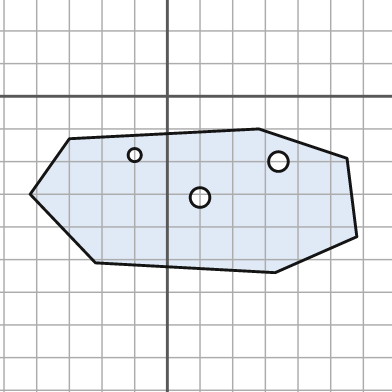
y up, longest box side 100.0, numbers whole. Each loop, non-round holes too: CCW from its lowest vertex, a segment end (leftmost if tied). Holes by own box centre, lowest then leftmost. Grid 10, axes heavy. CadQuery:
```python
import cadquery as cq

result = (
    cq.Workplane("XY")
    .moveTo(33.0, -54.0)
    .lineTo(58.0, -43.0)
    .lineTo(55.0, -19.0)
    .lineTo(28.0, -10.0)
    .lineTo(-30.0, -13.0)
    .lineTo(-42.0, -30.0)
    .lineTo(-22.0, -51.0)
    .close()
    .moveTo(10.0, -31.0)
    .circle(3.0)
    .moveTo(34.0, -20.0)
    .circle(3.0)
    .moveTo(-10.0, -18.0)
    .circle(2.0)
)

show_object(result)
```